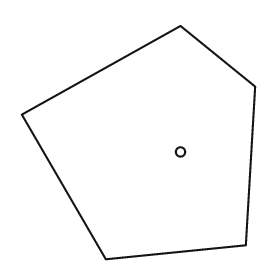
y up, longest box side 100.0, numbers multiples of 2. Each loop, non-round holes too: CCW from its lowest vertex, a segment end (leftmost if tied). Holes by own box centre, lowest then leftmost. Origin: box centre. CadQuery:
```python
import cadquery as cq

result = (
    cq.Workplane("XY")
    .moveTo(-14.0, -50.0)
    .lineTo(46.0, -44.0)
    .lineTo(50.0, 24.0)
    .lineTo(18.0, 50.0)
    .lineTo(-50.0, 12.0)
    .close()
    .moveTo(18.0, -4.0)
    .circle(2.0)
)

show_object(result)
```